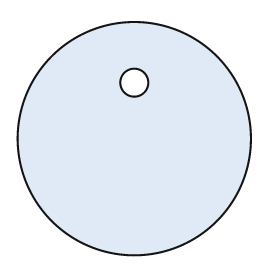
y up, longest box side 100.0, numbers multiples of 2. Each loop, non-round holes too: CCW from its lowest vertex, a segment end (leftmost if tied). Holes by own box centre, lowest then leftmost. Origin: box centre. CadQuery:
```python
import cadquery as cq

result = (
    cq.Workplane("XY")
    .moveTo(0.0, 0.0)
    .circle(50.0)
    .moveTo(0.0, 24.0)
    .circle(6.0)
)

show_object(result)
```